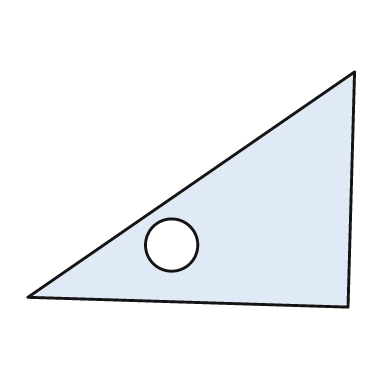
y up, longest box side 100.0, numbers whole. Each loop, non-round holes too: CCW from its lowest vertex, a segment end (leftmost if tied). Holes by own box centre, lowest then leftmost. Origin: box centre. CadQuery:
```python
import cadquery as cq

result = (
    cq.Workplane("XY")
    .moveTo(48.0, -36.0)
    .lineTo(50.0, 36.0)
    .lineTo(-50.0, -33.0)
    .close()
    .moveTo(-6.0, -17.0)
    .circle(8.0)
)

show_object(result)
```